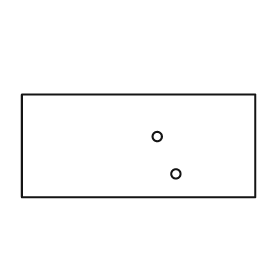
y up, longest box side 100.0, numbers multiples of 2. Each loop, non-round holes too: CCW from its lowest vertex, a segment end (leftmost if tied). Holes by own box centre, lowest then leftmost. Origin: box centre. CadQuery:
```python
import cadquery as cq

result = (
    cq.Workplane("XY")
    .moveTo(-50.0, -22.0)
    .lineTo(50.0, -22.0)
    .lineTo(50.0, 22.0)
    .lineTo(-50.0, 22.0)
    .close()
    .moveTo(16.0, -12.0)
    .circle(2.0)
    .moveTo(8.0, 4.0)
    .circle(2.0)
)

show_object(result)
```